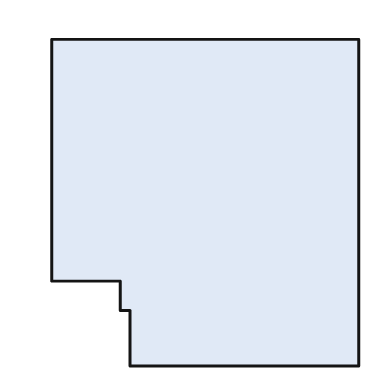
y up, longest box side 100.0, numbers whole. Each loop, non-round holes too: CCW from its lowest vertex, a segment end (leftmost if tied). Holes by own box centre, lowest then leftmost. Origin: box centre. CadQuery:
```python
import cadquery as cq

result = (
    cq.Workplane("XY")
    .moveTo(-23.0, -50.0)
    .lineTo(47.0, -50.0)
    .lineTo(47.0, 50.0)
    .lineTo(-47.0, 50.0)
    .lineTo(-47.0, -24.0)
    .lineTo(-26.0, -24.0)
    .lineTo(-26.0, -33.0)
    .lineTo(-23.0, -33.0)
    .close()
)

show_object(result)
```